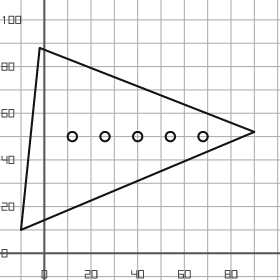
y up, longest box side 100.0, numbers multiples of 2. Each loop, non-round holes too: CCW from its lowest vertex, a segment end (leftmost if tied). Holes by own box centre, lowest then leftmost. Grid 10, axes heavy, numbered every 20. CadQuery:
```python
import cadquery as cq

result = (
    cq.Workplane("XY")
    .moveTo(-10.0, 10.0)
    .lineTo(90.0, 52.0)
    .lineTo(-2.0, 88.0)
    .close()
    .moveTo(12.0, 50.0)
    .circle(2.0)
    .moveTo(26.0, 50.0)
    .circle(2.0)
    .moveTo(40.0, 50.0)
    .circle(2.0)
    .moveTo(54.0, 50.0)
    .circle(2.0)
    .moveTo(68.0, 50.0)
    .circle(2.0)
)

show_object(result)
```